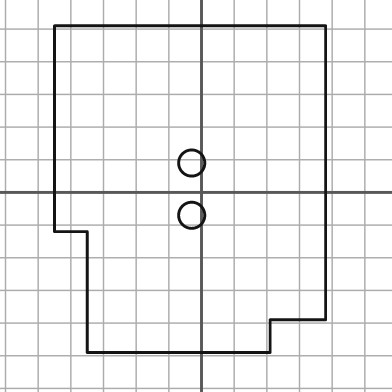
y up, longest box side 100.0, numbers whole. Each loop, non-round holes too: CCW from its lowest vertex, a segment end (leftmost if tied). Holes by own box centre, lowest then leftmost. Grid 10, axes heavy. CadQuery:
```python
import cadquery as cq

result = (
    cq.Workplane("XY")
    .moveTo(-35.0, -49.0)
    .lineTo(21.0, -49.0)
    .lineTo(21.0, -39.0)
    .lineTo(38.0, -39.0)
    .lineTo(38.0, 51.0)
    .lineTo(-45.0, 51.0)
    .lineTo(-45.0, -12.0)
    .lineTo(-35.0, -12.0)
    .close()
    .moveTo(-3.0, -7.0)
    .circle(4.0)
    .moveTo(-3.0, 9.0)
    .circle(4.0)
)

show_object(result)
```